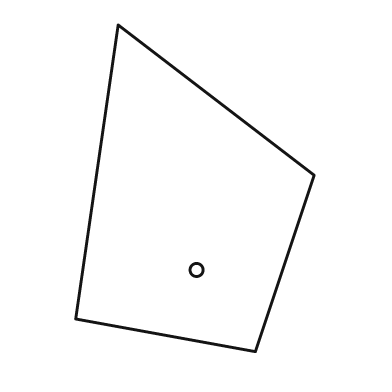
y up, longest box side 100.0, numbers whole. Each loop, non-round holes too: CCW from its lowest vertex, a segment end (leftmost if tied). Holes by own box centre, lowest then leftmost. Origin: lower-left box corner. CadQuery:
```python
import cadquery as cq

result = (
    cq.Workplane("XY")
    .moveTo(55.0, 0.0)
    .lineTo(73.0, 54.0)
    .lineTo(13.0, 100.0)
    .lineTo(0.0, 10.0)
    .close()
    .moveTo(37.0, 25.0)
    .circle(2.0)
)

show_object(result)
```